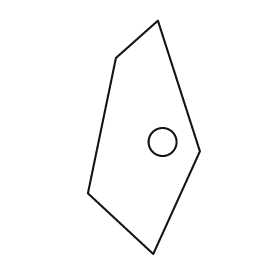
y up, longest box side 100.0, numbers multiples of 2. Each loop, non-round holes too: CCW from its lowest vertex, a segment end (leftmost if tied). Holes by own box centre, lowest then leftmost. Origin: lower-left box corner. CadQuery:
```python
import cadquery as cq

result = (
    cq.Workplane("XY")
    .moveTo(28.0, 0.0)
    .lineTo(48.0, 44.0)
    .lineTo(30.0, 100.0)
    .lineTo(12.0, 84.0)
    .lineTo(0.0, 26.0)
    .close()
    .moveTo(32.0, 48.0)
    .circle(6.0)
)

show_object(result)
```